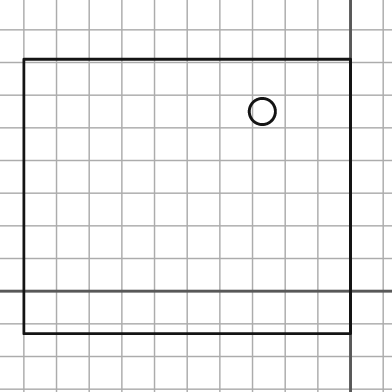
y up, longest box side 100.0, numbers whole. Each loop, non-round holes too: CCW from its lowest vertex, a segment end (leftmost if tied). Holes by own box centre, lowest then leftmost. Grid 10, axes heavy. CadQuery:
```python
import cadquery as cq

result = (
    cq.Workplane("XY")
    .moveTo(-100.0, -13.0)
    .lineTo(0.0, -13.0)
    .lineTo(0.0, 71.0)
    .lineTo(-100.0, 71.0)
    .close()
    .moveTo(-27.0, 55.0)
    .circle(4.0)
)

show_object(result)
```